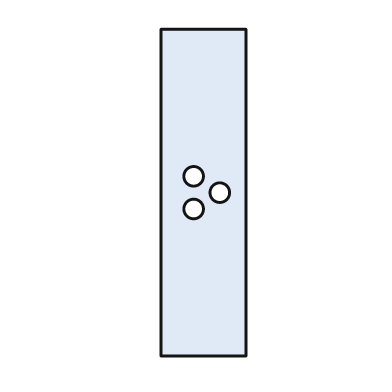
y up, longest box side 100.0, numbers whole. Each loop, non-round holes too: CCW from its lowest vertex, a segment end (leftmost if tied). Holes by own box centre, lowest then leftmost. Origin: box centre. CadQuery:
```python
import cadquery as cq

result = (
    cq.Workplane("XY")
    .moveTo(-13.0, -50.0)
    .lineTo(13.0, -50.0)
    .lineTo(13.0, 50.0)
    .lineTo(-13.0, 50.0)
    .close()
    .moveTo(-3.0, -5.0)
    .circle(3.0)
    .moveTo(5.0, 0.0)
    .circle(3.0)
    .moveTo(-3.0, 5.0)
    .circle(3.0)
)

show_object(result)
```